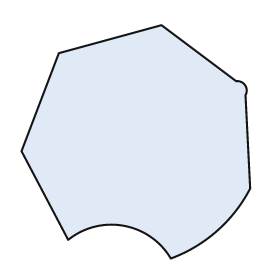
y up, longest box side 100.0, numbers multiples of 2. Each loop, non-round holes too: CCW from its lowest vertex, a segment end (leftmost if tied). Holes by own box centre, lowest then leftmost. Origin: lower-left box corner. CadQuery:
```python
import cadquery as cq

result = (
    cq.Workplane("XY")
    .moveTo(64.0, 0.0)
    .threePointArc((84.0, 12.0), (98.0, 30.0))
    .lineTo(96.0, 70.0)
    .threePointArc((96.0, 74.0), (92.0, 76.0))
    .lineTo(60.0, 100.0)
    .lineTo(16.0, 88.0)
    .lineTo(0.0, 46.0)
    .lineTo(20.0, 8.0)
    .threePointArc((44.0, 14.0), (64.0, 0.0))
    .close()
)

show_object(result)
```